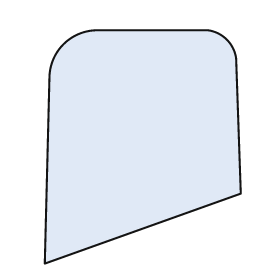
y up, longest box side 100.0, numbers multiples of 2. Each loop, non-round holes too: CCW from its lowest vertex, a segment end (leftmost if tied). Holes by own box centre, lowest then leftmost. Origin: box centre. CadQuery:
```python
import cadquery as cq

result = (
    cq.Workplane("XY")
    .moveTo(-42.0, -50.0)
    .lineTo(42.0, -20.0)
    .lineTo(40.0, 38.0)
    .threePointArc((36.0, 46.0), (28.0, 50.0))
    .lineTo(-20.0, 50.0)
    .threePointArc((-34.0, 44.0), (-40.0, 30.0))
    .close()
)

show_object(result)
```